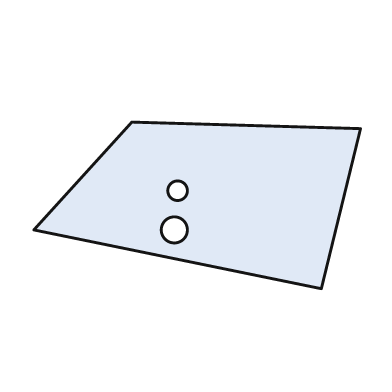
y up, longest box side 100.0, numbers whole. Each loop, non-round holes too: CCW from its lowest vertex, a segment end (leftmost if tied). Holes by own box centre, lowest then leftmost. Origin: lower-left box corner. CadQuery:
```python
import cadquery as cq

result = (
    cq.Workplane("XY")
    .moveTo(88.0, 0.0)
    .lineTo(100.0, 49.0)
    .lineTo(30.0, 51.0)
    .lineTo(0.0, 18.0)
    .close()
    .moveTo(43.0, 18.0)
    .circle(4.0)
    .moveTo(44.0, 30.0)
    .circle(3.0)
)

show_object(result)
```